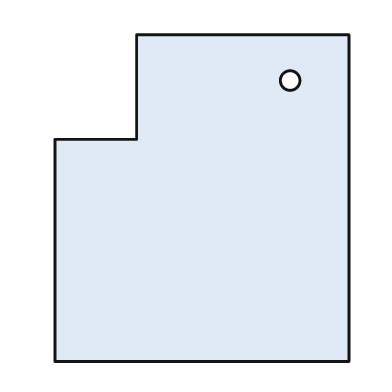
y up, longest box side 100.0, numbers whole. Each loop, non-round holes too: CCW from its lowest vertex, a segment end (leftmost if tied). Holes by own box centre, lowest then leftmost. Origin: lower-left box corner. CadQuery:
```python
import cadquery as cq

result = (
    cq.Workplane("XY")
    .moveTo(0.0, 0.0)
    .lineTo(90.0, 0.0)
    .lineTo(90.0, 100.0)
    .lineTo(25.0, 100.0)
    .lineTo(25.0, 68.0)
    .lineTo(0.0, 68.0)
    .close()
    .moveTo(72.0, 86.0)
    .circle(3.0)
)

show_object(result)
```